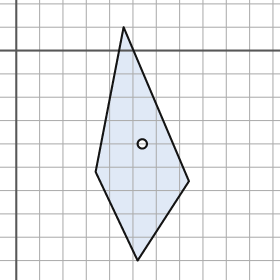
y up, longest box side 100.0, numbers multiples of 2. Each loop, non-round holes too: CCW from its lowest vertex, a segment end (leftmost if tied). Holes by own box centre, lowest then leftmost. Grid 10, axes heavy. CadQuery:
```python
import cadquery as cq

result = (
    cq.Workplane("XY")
    .moveTo(52.0, -90.0)
    .lineTo(74.0, -56.0)
    .lineTo(46.0, 10.0)
    .lineTo(34.0, -52.0)
    .close()
    .moveTo(54.0, -40.0)
    .circle(2.0)
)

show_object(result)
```